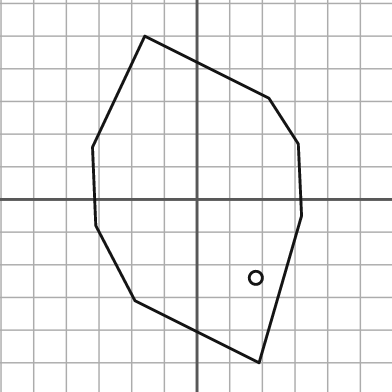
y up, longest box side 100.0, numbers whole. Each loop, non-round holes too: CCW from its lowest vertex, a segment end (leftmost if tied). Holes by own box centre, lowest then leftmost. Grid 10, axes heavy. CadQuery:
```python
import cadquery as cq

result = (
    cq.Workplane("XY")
    .moveTo(19.0, -50.0)
    .lineTo(32.0, -5.0)
    .lineTo(31.0, 17.0)
    .lineTo(22.0, 31.0)
    .lineTo(-16.0, 50.0)
    .lineTo(-32.0, 16.0)
    .lineTo(-31.0, -8.0)
    .lineTo(-19.0, -31.0)
    .close()
    .moveTo(18.0, -24.0)
    .circle(2.0)
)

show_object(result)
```